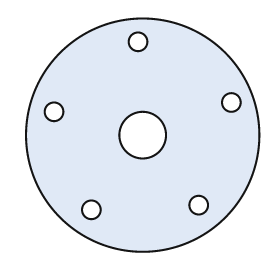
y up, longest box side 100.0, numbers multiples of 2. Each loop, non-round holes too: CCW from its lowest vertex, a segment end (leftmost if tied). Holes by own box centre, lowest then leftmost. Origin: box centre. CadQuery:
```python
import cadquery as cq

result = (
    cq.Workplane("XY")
    .moveTo(0.0, 0.0)
    .circle(50.0)
    .moveTo(-22.0, -32.0)
    .circle(4.0)
    .moveTo(24.0, -30.0)
    .circle(4.0)
    .moveTo(0.0, 0.0)
    .circle(10.0)
    .moveTo(-38.0, 10.0)
    .circle(4.0)
    .moveTo(38.0, 14.0)
    .circle(4.0)
    .moveTo(-2.0, 40.0)
    .circle(4.0)
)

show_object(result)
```